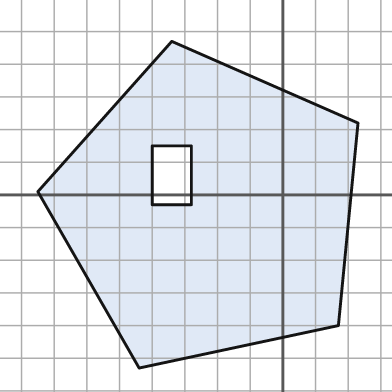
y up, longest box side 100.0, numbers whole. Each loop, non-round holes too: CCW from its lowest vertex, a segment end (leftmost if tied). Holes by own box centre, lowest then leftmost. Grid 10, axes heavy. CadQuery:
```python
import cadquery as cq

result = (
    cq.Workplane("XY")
    .moveTo(-44.0, -53.0)
    .lineTo(17.0, -40.0)
    .lineTo(23.0, 22.0)
    .lineTo(-34.0, 47.0)
    .lineTo(-75.0, 1.0)
    .close()
    .moveTo(-40.0, -3.0)
    .lineTo(-28.0, -3.0)
    .lineTo(-28.0, 15.0)
    .lineTo(-40.0, 15.0)
    .close()
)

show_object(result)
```